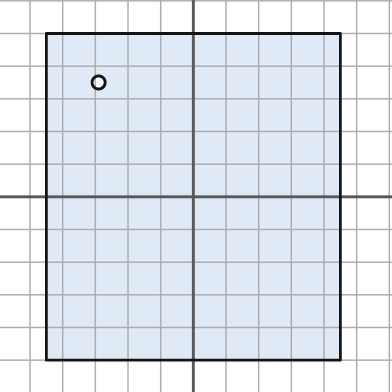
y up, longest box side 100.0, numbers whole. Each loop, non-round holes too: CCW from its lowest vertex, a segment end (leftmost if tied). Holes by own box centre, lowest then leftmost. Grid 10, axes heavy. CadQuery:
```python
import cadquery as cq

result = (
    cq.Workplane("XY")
    .moveTo(-45.0, -50.0)
    .lineTo(45.0, -50.0)
    .lineTo(45.0, 50.0)
    .lineTo(-45.0, 50.0)
    .close()
    .moveTo(-29.0, 35.0)
    .circle(2.0)
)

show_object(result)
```